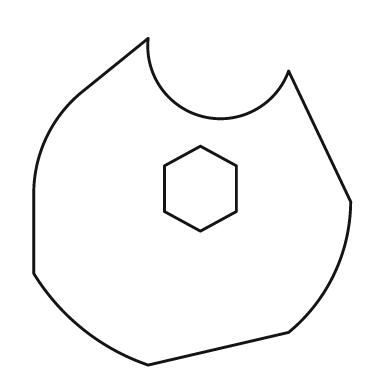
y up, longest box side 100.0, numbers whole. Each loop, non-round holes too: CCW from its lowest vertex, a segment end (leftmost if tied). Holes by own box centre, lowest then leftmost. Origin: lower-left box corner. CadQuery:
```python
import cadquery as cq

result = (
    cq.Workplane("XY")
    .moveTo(35.0, 0.0)
    .lineTo(78.0, 10.0)
    .threePointArc((92.0, 28.0), (97.0, 50.0))
    .lineTo(78.0, 90.0)
    .threePointArc((52.0, 76.0), (35.0, 100.0))
    .lineTo(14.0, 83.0)
    .threePointArc((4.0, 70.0), (0.0, 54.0))
    .lineTo(0.0, 28.0)
    .threePointArc((15.0, 11.0), (35.0, 0.0))
    .close()
    .moveTo(51.0, 41.0)
    .lineTo(62.0, 47.0)
    .lineTo(62.0, 61.0)
    .lineTo(51.0, 67.0)
    .lineTo(40.0, 61.0)
    .lineTo(40.0, 47.0)
    .close()
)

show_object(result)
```